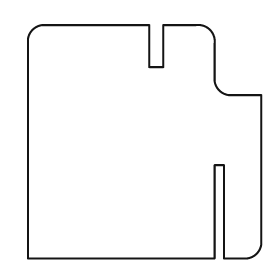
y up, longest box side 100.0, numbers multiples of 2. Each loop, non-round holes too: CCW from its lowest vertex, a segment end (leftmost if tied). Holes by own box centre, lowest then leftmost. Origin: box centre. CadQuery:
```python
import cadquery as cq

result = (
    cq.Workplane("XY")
    .moveTo(-50.0, -50.0)
    .lineTo(30.0, -50.0)
    .lineTo(30.0, -10.0)
    .lineTo(34.0, -10.0)
    .lineTo(34.0, -50.0)
    .lineTo(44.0, -50.0)
    .threePointArc((48.0, -48.0), (50.0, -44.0))
    .lineTo(50.0, 20.0)
    .lineTo(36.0, 20.0)
    .threePointArc((32.0, 22.0), (30.0, 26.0))
    .lineTo(30.0, 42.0)
    .threePointArc((28.0, 48.0), (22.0, 50.0))
    .lineTo(8.0, 50.0)
    .lineTo(8.0, 32.0)
    .lineTo(2.0, 32.0)
    .lineTo(2.0, 50.0)
    .lineTo(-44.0, 50.0)
    .threePointArc((-48.0, 48.0), (-50.0, 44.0))
    .close()
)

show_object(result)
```